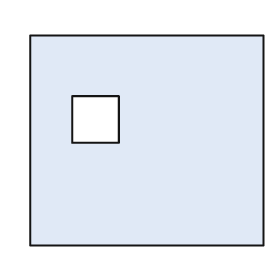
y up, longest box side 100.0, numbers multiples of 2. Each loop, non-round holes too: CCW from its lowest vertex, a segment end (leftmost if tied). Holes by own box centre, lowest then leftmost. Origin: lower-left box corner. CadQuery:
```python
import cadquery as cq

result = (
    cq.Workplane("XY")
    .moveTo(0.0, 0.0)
    .lineTo(100.0, 0.0)
    .lineTo(100.0, 90.0)
    .lineTo(0.0, 90.0)
    .close()
    .moveTo(18.0, 44.0)
    .lineTo(38.0, 44.0)
    .lineTo(38.0, 64.0)
    .lineTo(18.0, 64.0)
    .close()
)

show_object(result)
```